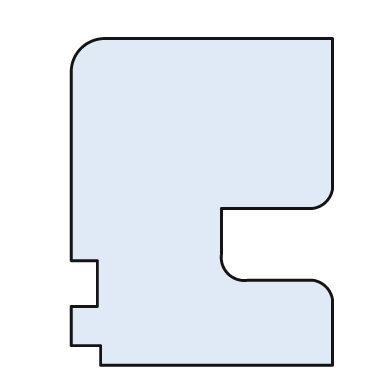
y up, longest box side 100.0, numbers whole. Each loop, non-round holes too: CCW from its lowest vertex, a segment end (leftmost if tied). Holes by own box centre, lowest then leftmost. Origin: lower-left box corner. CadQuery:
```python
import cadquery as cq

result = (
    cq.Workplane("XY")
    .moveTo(9.0, 0.0)
    .lineTo(80.0, 0.0)
    .lineTo(80.0, 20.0)
    .threePointArc((78.0, 24.0), (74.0, 26.0))
    .lineTo(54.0, 26.0)
    .threePointArc((48.0, 28.0), (46.0, 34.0))
    .lineTo(46.0, 48.0)
    .lineTo(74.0, 48.0)
    .threePointArc((78.0, 50.0), (80.0, 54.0))
    .lineTo(80.0, 100.0)
    .lineTo(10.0, 100.0)
    .threePointArc((3.0, 97.0), (0.0, 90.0))
    .lineTo(0.0, 32.0)
    .lineTo(8.0, 32.0)
    .lineTo(8.0, 18.0)
    .lineTo(0.0, 18.0)
    .lineTo(0.0, 6.0)
    .lineTo(9.0, 6.0)
    .close()
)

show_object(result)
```